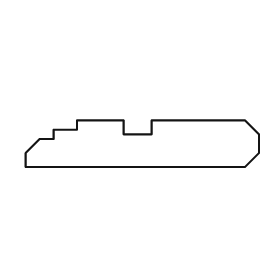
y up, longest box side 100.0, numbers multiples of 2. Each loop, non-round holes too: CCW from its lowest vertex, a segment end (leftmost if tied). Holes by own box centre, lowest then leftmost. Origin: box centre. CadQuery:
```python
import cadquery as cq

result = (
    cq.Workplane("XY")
    .moveTo(-50.0, -10.0)
    .lineTo(44.0, -10.0)
    .lineTo(50.0, -4.0)
    .lineTo(50.0, 4.0)
    .lineTo(44.0, 10.0)
    .lineTo(4.0, 10.0)
    .lineTo(4.0, 4.0)
    .lineTo(-8.0, 4.0)
    .lineTo(-8.0, 10.0)
    .lineTo(-28.0, 10.0)
    .lineTo(-28.0, 6.0)
    .lineTo(-38.0, 6.0)
    .lineTo(-38.0, 2.0)
    .lineTo(-44.0, 2.0)
    .lineTo(-50.0, -4.0)
    .close()
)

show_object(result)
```